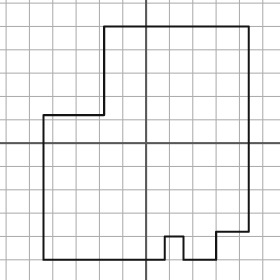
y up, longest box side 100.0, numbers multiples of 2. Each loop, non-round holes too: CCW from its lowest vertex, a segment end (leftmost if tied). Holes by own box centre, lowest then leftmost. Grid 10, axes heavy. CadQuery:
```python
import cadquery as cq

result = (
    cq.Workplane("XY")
    .moveTo(-44.0, -50.0)
    .lineTo(8.0, -50.0)
    .lineTo(8.0, -40.0)
    .lineTo(16.0, -40.0)
    .lineTo(16.0, -50.0)
    .lineTo(30.0, -50.0)
    .lineTo(30.0, -38.0)
    .lineTo(44.0, -38.0)
    .lineTo(44.0, 50.0)
    .lineTo(-18.0, 50.0)
    .lineTo(-18.0, 12.0)
    .lineTo(-44.0, 12.0)
    .close()
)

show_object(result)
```